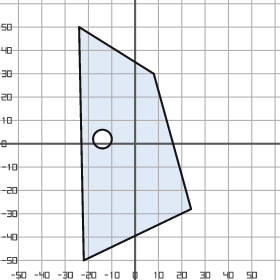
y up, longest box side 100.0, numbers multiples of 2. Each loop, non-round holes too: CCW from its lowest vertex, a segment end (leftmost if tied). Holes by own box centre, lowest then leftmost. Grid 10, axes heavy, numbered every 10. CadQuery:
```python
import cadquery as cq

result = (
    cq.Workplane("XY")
    .moveTo(-22.0, -50.0)
    .lineTo(24.0, -28.0)
    .lineTo(8.0, 30.0)
    .lineTo(-24.0, 50.0)
    .close()
    .moveTo(-14.0, 2.0)
    .circle(4.0)
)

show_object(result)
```